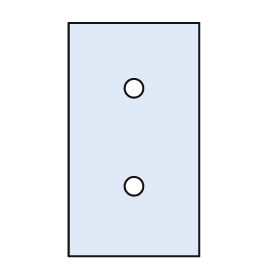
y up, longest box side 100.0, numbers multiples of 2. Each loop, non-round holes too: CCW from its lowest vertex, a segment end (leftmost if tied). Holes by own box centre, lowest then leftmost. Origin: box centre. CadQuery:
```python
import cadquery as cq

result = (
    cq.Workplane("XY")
    .moveTo(-28.0, -50.0)
    .lineTo(28.0, -50.0)
    .lineTo(28.0, 50.0)
    .lineTo(-28.0, 50.0)
    .close()
    .moveTo(0.0, -20.0)
    .circle(4.0)
    .moveTo(0.0, 22.0)
    .circle(4.0)
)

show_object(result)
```